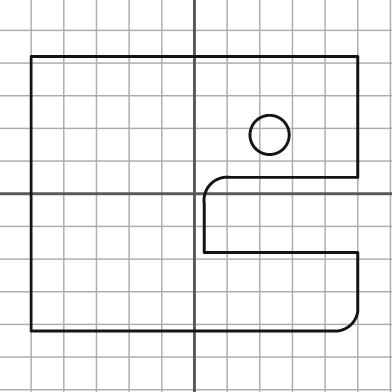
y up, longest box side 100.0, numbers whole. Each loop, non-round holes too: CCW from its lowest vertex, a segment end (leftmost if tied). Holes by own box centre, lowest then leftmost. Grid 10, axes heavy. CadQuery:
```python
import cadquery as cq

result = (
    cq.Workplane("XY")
    .moveTo(-50.0, -42.0)
    .lineTo(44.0, -42.0)
    .threePointArc((48.0, -40.0), (50.0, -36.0))
    .lineTo(50.0, -18.0)
    .lineTo(3.0, -18.0)
    .lineTo(3.0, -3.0)
    .threePointArc((5.0, 3.0), (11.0, 5.0))
    .lineTo(50.0, 5.0)
    .lineTo(50.0, 42.0)
    .lineTo(-50.0, 42.0)
    .close()
    .moveTo(23.0, 18.0)
    .circle(6.0)
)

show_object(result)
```